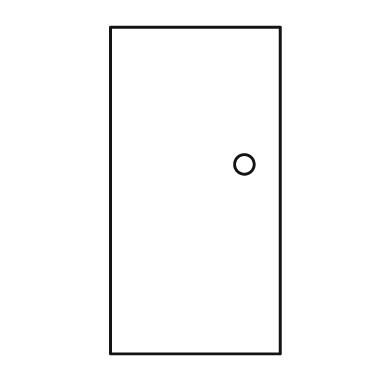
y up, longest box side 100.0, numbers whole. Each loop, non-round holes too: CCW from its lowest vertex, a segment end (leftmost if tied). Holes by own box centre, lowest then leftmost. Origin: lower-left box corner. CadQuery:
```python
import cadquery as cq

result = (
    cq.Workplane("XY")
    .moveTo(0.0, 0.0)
    .lineTo(52.0, 0.0)
    .lineTo(52.0, 100.0)
    .lineTo(0.0, 100.0)
    .close()
    .moveTo(41.0, 58.0)
    .circle(3.0)
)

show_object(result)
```